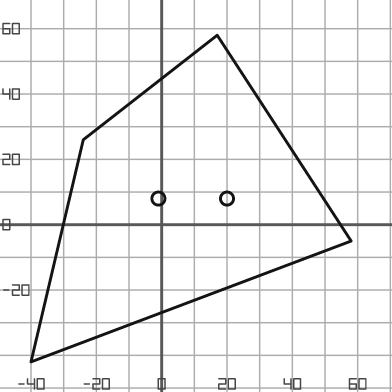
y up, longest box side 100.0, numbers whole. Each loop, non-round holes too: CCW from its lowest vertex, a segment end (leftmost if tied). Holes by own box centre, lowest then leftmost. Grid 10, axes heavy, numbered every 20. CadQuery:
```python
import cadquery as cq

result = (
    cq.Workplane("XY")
    .moveTo(-40.0, -42.0)
    .lineTo(58.0, -5.0)
    .lineTo(17.0, 58.0)
    .lineTo(-24.0, 26.0)
    .close()
    .moveTo(-1.0, 8.0)
    .circle(2.0)
    .moveTo(20.0, 8.0)
    .circle(2.0)
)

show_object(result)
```